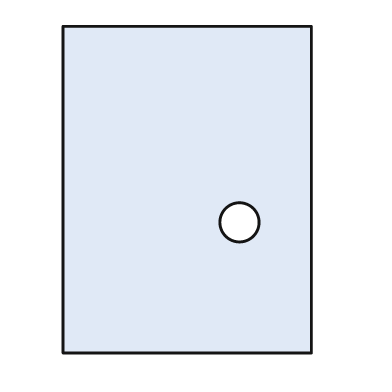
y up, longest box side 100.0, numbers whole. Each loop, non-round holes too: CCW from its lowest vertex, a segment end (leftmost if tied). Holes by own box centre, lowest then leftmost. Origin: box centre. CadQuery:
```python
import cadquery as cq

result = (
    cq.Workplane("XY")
    .moveTo(-38.0, -50.0)
    .lineTo(38.0, -50.0)
    .lineTo(38.0, 50.0)
    .lineTo(-38.0, 50.0)
    .close()
    .moveTo(16.0, -10.0)
    .circle(6.0)
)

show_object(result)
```